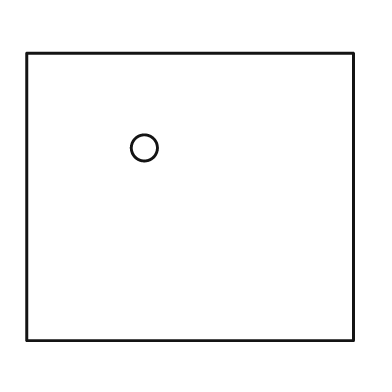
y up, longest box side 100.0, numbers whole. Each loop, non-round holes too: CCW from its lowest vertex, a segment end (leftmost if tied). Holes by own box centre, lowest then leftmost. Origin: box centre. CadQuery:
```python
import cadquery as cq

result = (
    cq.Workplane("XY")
    .moveTo(-50.0, -44.0)
    .lineTo(50.0, -44.0)
    .lineTo(50.0, 44.0)
    .lineTo(-50.0, 44.0)
    .close()
    .moveTo(-14.0, 15.0)
    .circle(4.0)
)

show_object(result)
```